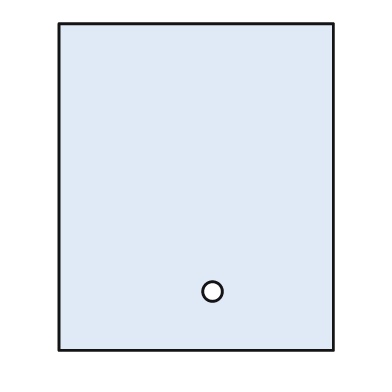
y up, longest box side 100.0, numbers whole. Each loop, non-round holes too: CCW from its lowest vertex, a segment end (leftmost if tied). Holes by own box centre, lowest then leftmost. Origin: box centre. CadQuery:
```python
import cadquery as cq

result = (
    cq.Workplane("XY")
    .moveTo(-42.0, -50.0)
    .lineTo(42.0, -50.0)
    .lineTo(42.0, 50.0)
    .lineTo(-42.0, 50.0)
    .close()
    .moveTo(5.0, -32.0)
    .circle(3.0)
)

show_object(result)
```